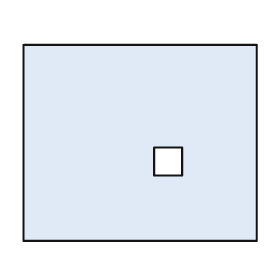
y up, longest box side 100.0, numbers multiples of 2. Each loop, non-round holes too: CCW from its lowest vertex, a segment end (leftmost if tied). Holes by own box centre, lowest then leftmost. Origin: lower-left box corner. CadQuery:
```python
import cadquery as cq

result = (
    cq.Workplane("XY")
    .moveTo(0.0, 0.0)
    .lineTo(100.0, 0.0)
    .lineTo(100.0, 84.0)
    .lineTo(0.0, 84.0)
    .close()
    .moveTo(56.0, 28.0)
    .lineTo(68.0, 28.0)
    .lineTo(68.0, 40.0)
    .lineTo(56.0, 40.0)
    .close()
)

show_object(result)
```